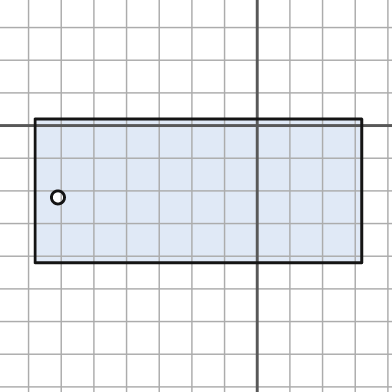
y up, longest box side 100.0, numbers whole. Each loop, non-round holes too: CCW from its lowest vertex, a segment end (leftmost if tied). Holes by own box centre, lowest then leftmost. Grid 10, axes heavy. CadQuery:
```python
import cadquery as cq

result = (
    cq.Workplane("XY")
    .moveTo(-68.0, -42.0)
    .lineTo(32.0, -42.0)
    .lineTo(32.0, 2.0)
    .lineTo(-68.0, 2.0)
    .close()
    .moveTo(-61.0, -22.0)
    .circle(2.0)
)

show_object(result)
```